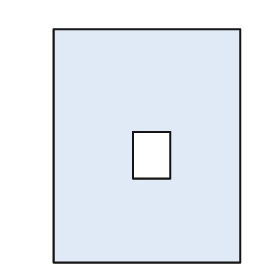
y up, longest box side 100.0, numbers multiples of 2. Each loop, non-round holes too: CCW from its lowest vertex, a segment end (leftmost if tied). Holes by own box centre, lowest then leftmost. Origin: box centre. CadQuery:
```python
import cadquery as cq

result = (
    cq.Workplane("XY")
    .moveTo(-40.0, -50.0)
    .lineTo(40.0, -50.0)
    .lineTo(40.0, 50.0)
    .lineTo(-40.0, 50.0)
    .close()
    .moveTo(-6.0, -14.0)
    .lineTo(10.0, -14.0)
    .lineTo(10.0, 6.0)
    .lineTo(-6.0, 6.0)
    .close()
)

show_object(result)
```